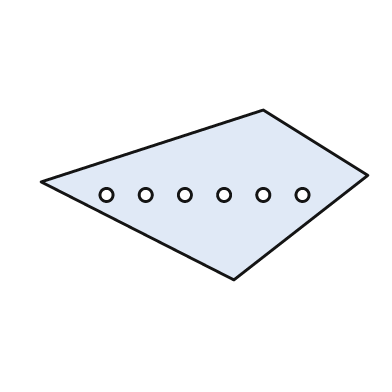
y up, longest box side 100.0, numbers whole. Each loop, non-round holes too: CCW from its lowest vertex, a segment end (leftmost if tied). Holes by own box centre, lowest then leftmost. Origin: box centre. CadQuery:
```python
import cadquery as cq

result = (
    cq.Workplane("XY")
    .moveTo(9.0, -26.0)
    .lineTo(50.0, 6.0)
    .lineTo(18.0, 26.0)
    .lineTo(-50.0, 4.0)
    .close()
    .moveTo(-30.0, 0.0)
    .circle(2.0)
    .moveTo(-18.0, 0.0)
    .circle(2.0)
    .moveTo(-6.0, 0.0)
    .circle(2.0)
    .moveTo(6.0, 0.0)
    .circle(2.0)
    .moveTo(18.0, 0.0)
    .circle(2.0)
    .moveTo(30.0, 0.0)
    .circle(2.0)
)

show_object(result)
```